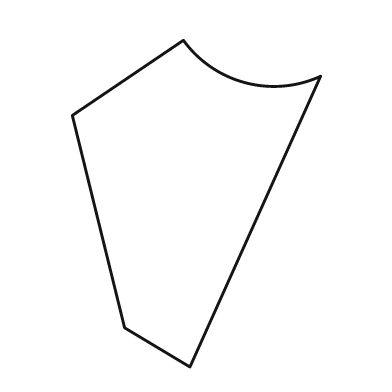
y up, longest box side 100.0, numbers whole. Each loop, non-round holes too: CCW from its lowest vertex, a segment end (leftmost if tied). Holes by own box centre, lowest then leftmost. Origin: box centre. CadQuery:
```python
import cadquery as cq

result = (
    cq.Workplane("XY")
    .moveTo(-2.0, -50.0)
    .lineTo(38.0, 39.0)
    .threePointArc((15.0, 37.0), (-4.0, 50.0))
    .lineTo(-38.0, 27.0)
    .lineTo(-22.0, -38.0)
    .close()
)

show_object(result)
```